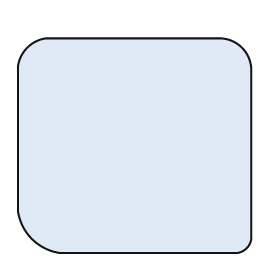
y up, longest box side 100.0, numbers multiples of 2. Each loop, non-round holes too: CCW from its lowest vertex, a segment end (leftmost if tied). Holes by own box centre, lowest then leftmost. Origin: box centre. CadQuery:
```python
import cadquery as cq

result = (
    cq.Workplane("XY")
    .moveTo(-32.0, -46.0)
    .lineTo(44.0, -46.0)
    .threePointArc((48.0, -44.0), (50.0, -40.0))
    .lineTo(50.0, 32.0)
    .threePointArc((46.0, 42.0), (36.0, 46.0))
    .lineTo(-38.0, 46.0)
    .threePointArc((-46.0, 42.0), (-50.0, 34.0))
    .lineTo(-50.0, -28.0)
    .threePointArc((-44.0, -40.0), (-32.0, -46.0))
    .close()
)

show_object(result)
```